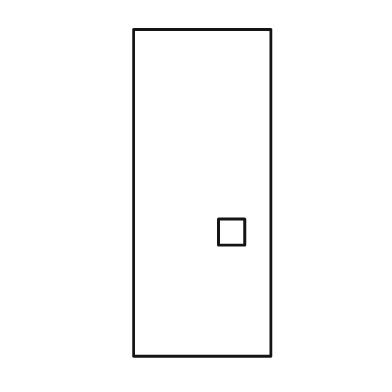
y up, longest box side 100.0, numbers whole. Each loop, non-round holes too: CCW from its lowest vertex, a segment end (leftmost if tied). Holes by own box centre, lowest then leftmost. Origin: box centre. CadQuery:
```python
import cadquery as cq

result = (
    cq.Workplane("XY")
    .moveTo(-21.0, -50.0)
    .lineTo(21.0, -50.0)
    .lineTo(21.0, 50.0)
    .lineTo(-21.0, 50.0)
    .close()
    .moveTo(5.0, -16.0)
    .lineTo(13.0, -16.0)
    .lineTo(13.0, -8.0)
    .lineTo(5.0, -8.0)
    .close()
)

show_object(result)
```